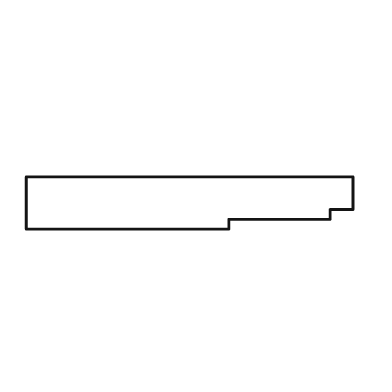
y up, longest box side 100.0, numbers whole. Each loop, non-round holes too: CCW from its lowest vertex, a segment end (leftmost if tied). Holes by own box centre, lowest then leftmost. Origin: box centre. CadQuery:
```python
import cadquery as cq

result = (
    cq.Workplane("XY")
    .moveTo(-50.0, -8.0)
    .lineTo(12.0, -8.0)
    .lineTo(12.0, -5.0)
    .lineTo(43.0, -5.0)
    .lineTo(43.0, -2.0)
    .lineTo(50.0, -2.0)
    .lineTo(50.0, 8.0)
    .lineTo(-50.0, 8.0)
    .close()
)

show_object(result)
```